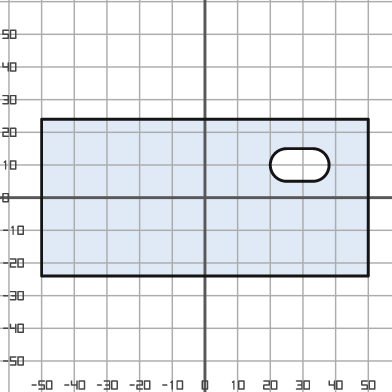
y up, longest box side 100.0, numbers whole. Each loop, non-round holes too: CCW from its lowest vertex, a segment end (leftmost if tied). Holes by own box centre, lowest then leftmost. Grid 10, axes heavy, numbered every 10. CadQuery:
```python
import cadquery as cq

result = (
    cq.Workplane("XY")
    .moveTo(-50.0, -24.0)
    .lineTo(50.0, -24.0)
    .lineTo(50.0, 24.0)
    .lineTo(-50.0, 24.0)
    .close()
    .moveTo(25.0, 5.0)
    .lineTo(33.0, 5.0)
    .threePointArc((38.0, 10.0), (33.0, 15.0))
    .lineTo(25.0, 15.0)
    .threePointArc((20.0, 10.0), (25.0, 5.0))
    .close()
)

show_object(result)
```